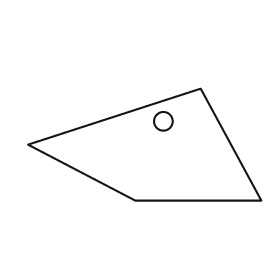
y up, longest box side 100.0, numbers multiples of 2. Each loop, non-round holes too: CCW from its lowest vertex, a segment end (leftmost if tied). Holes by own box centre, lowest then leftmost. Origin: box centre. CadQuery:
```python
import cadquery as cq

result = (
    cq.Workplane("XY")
    .moveTo(-4.0, -24.0)
    .lineTo(50.0, -24.0)
    .lineTo(24.0, 24.0)
    .lineTo(-50.0, 0.0)
    .close()
    .moveTo(8.0, 10.0)
    .circle(4.0)
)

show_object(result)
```